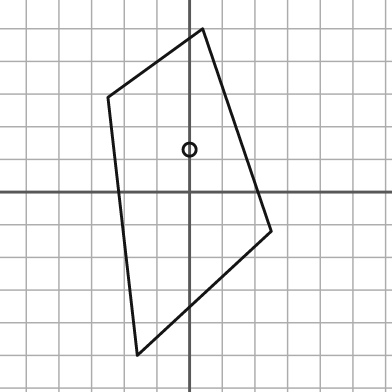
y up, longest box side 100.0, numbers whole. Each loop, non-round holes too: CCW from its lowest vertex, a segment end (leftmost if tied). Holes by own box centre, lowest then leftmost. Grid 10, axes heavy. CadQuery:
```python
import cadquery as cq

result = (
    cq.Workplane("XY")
    .moveTo(-16.0, -50.0)
    .lineTo(25.0, -12.0)
    .lineTo(4.0, 50.0)
    .lineTo(-25.0, 29.0)
    .close()
    .moveTo(0.0, 13.0)
    .circle(2.0)
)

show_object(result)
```